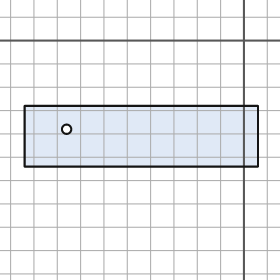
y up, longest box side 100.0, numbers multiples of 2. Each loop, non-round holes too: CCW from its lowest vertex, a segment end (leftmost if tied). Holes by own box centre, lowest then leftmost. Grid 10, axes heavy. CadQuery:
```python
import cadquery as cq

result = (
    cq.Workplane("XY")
    .moveTo(-94.0, -54.0)
    .lineTo(6.0, -54.0)
    .lineTo(6.0, -28.0)
    .lineTo(-94.0, -28.0)
    .close()
    .moveTo(-76.0, -38.0)
    .circle(2.0)
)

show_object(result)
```